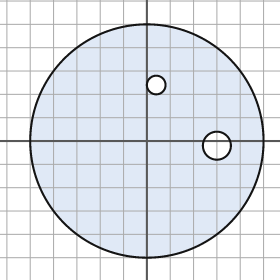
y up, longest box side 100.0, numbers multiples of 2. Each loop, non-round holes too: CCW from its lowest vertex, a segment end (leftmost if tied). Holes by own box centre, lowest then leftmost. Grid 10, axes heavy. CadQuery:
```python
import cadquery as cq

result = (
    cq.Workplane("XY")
    .moveTo(0.0, 0.0)
    .circle(50.0)
    .moveTo(30.0, -2.0)
    .circle(6.0)
    .moveTo(4.0, 24.0)
    .circle(4.0)
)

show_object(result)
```